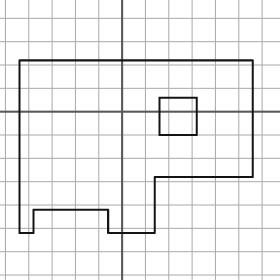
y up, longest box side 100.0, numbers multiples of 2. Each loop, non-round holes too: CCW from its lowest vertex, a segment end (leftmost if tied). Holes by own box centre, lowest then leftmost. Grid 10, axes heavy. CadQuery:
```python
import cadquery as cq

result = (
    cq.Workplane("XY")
    .moveTo(-44.0, -52.0)
    .lineTo(-38.0, -52.0)
    .lineTo(-38.0, -42.0)
    .lineTo(-6.0, -42.0)
    .lineTo(-6.0, -52.0)
    .lineTo(14.0, -52.0)
    .lineTo(14.0, -28.0)
    .lineTo(56.0, -28.0)
    .lineTo(56.0, 22.0)
    .lineTo(-44.0, 22.0)
    .close()
    .moveTo(16.0, -10.0)
    .lineTo(32.0, -10.0)
    .lineTo(32.0, 6.0)
    .lineTo(16.0, 6.0)
    .close()
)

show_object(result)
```